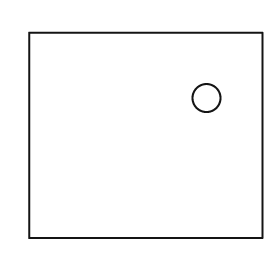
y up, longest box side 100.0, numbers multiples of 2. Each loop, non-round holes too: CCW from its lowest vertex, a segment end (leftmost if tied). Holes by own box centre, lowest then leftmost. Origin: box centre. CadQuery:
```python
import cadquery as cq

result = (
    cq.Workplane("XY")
    .moveTo(-50.0, -44.0)
    .lineTo(50.0, -44.0)
    .lineTo(50.0, 44.0)
    .lineTo(-50.0, 44.0)
    .close()
    .moveTo(26.0, 16.0)
    .circle(6.0)
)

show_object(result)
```